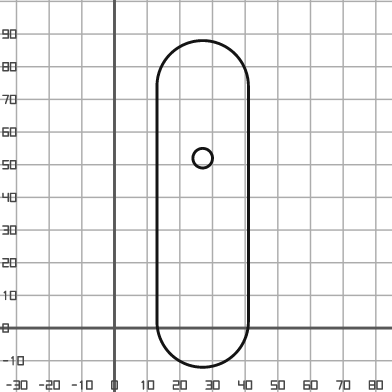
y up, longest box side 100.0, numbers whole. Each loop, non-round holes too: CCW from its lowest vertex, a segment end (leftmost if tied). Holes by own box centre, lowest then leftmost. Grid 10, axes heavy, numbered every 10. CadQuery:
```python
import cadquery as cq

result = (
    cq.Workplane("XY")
    .moveTo(13.0, 2.0)
    .threePointArc((27.0, -12.0), (41.0, 2.0))
    .lineTo(41.0, 74.0)
    .threePointArc((27.0, 88.0), (13.0, 74.0))
    .close()
    .moveTo(27.0, 52.0)
    .circle(3.0)
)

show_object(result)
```